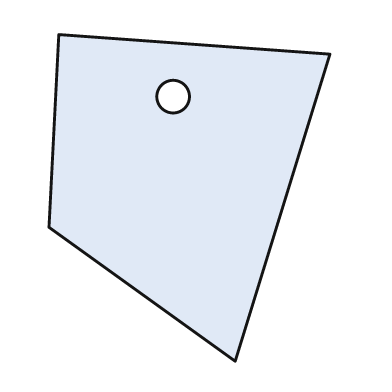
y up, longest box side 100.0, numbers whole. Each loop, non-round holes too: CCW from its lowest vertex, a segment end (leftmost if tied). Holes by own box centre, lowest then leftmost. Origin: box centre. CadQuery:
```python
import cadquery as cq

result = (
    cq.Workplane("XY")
    .moveTo(14.0, -50.0)
    .lineTo(43.0, 44.0)
    .lineTo(-40.0, 50.0)
    .lineTo(-43.0, -9.0)
    .close()
    .moveTo(-5.0, 31.0)
    .circle(5.0)
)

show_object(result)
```